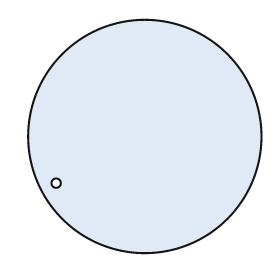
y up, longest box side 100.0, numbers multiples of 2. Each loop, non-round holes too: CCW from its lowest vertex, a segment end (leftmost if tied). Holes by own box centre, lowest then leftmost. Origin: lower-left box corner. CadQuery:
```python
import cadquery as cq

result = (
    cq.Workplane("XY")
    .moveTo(50.0, 50.0)
    .circle(50.0)
    .moveTo(12.0, 30.0)
    .circle(2.0)
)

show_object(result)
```